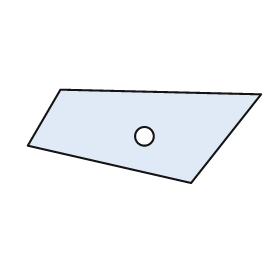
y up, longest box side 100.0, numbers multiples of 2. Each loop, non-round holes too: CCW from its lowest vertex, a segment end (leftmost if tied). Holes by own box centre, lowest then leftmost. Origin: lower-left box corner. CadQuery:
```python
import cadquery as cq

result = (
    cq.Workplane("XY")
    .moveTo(70.0, 0.0)
    .lineTo(100.0, 38.0)
    .lineTo(14.0, 40.0)
    .lineTo(0.0, 16.0)
    .close()
    .moveTo(50.0, 20.0)
    .circle(4.0)
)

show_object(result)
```